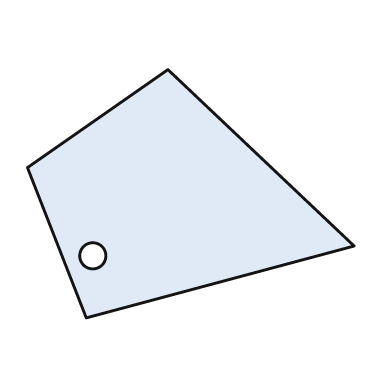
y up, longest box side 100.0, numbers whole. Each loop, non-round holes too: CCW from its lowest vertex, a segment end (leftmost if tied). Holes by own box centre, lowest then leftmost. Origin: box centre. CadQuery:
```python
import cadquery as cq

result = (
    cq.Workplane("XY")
    .moveTo(-32.0, -38.0)
    .lineTo(50.0, -16.0)
    .lineTo(-7.0, 38.0)
    .lineTo(-50.0, 8.0)
    .close()
    .moveTo(-30.0, -19.0)
    .circle(4.0)
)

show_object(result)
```